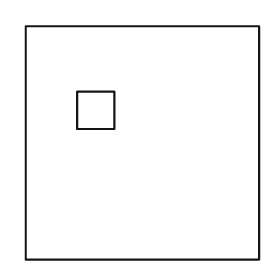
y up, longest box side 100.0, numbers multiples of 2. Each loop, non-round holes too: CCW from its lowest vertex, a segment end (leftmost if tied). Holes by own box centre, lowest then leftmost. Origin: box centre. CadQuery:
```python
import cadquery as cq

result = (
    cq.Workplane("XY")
    .moveTo(-50.0, -50.0)
    .lineTo(50.0, -50.0)
    .lineTo(50.0, 50.0)
    .lineTo(-50.0, 50.0)
    .close()
    .moveTo(-28.0, 6.0)
    .lineTo(-12.0, 6.0)
    .lineTo(-12.0, 22.0)
    .lineTo(-28.0, 22.0)
    .close()
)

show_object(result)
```